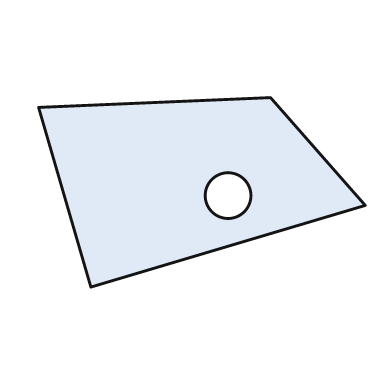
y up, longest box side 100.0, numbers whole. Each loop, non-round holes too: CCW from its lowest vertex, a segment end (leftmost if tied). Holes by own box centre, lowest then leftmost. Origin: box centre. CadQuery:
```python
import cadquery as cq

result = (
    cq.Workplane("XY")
    .moveTo(-34.0, -29.0)
    .lineTo(50.0, -4.0)
    .lineTo(21.0, 29.0)
    .lineTo(-50.0, 26.0)
    .close()
    .moveTo(8.0, -1.0)
    .circle(7.0)
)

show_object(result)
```